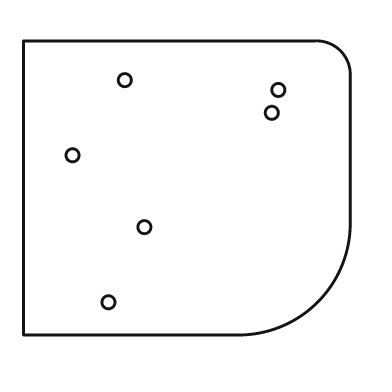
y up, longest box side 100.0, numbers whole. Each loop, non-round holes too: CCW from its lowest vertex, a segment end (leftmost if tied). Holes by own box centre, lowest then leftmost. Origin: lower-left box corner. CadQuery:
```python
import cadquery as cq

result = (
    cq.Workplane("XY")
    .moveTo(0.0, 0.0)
    .lineTo(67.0, 0.0)
    .threePointArc((90.0, 10.0), (100.0, 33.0))
    .lineTo(100.0, 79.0)
    .threePointArc((97.0, 87.0), (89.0, 90.0))
    .lineTo(0.0, 90.0)
    .close()
    .moveTo(26.0, 10.0)
    .circle(2.0)
    .moveTo(37.0, 33.0)
    .circle(2.0)
    .moveTo(15.0, 55.0)
    .circle(2.0)
    .moveTo(76.0, 68.0)
    .circle(2.0)
    .moveTo(78.0, 75.0)
    .circle(2.0)
    .moveTo(31.0, 78.0)
    .circle(2.0)
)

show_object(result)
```